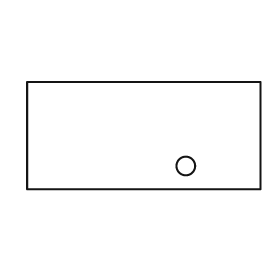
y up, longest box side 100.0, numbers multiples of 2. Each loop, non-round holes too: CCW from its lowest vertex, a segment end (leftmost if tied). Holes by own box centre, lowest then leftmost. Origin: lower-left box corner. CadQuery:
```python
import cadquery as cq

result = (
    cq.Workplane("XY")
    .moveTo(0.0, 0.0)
    .lineTo(100.0, 0.0)
    .lineTo(100.0, 46.0)
    .lineTo(0.0, 46.0)
    .close()
    .moveTo(68.0, 10.0)
    .circle(4.0)
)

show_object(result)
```